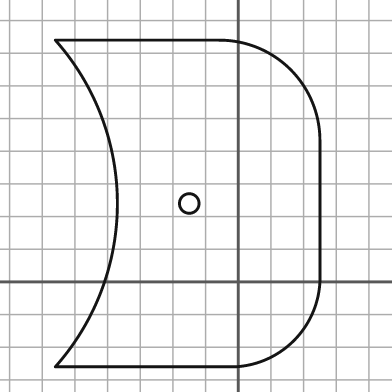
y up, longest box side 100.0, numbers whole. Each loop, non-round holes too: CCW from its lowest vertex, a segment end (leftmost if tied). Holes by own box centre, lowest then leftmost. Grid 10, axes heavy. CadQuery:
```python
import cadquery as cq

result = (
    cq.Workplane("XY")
    .moveTo(-56.0, -26.0)
    .lineTo(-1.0, -26.0)
    .threePointArc((17.0, -18.0), (25.0, 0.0))
    .lineTo(25.0, 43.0)
    .threePointArc((16.0, 65.0), (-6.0, 74.0))
    .lineTo(-56.0, 74.0)
    .threePointArc((-37.0, 24.0), (-56.0, -26.0))
    .close()
    .moveTo(-15.0, 24.0)
    .circle(3.0)
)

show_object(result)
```